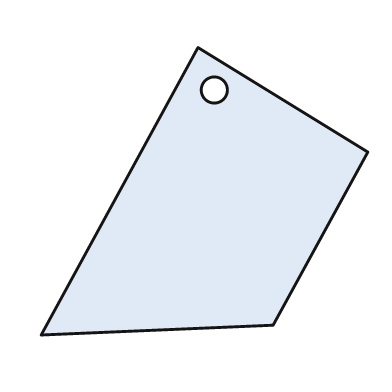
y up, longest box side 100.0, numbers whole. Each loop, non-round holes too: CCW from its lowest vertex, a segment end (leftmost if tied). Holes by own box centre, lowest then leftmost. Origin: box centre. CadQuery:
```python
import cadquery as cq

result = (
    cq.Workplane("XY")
    .moveTo(-50.0, -44.0)
    .lineTo(21.0, -41.0)
    .lineTo(50.0, 12.0)
    .lineTo(-2.0, 44.0)
    .close()
    .moveTo(3.0, 31.0)
    .circle(4.0)
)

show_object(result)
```